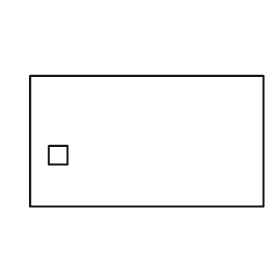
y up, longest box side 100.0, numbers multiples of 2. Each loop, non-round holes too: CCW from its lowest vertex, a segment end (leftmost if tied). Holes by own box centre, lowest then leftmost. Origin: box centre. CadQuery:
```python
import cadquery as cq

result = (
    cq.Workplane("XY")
    .moveTo(-50.0, -28.0)
    .lineTo(50.0, -28.0)
    .lineTo(50.0, 28.0)
    .lineTo(-50.0, 28.0)
    .close()
    .moveTo(-42.0, -10.0)
    .lineTo(-34.0, -10.0)
    .lineTo(-34.0, -2.0)
    .lineTo(-42.0, -2.0)
    .close()
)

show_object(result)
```